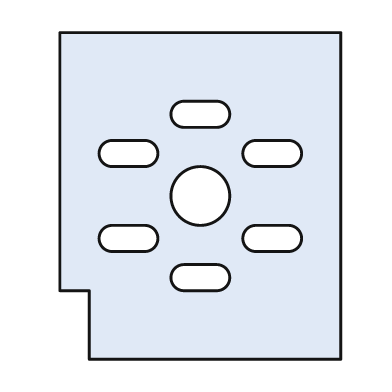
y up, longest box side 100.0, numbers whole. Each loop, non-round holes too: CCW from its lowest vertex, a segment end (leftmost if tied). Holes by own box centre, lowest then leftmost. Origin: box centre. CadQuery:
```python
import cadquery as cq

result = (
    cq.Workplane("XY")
    .moveTo(-34.0, -50.0)
    .lineTo(43.0, -50.0)
    .lineTo(43.0, 50.0)
    .lineTo(-43.0, 50.0)
    .lineTo(-43.0, -29.0)
    .lineTo(-34.0, -29.0)
    .close()
    .moveTo(-5.0, -29.0)
    .lineTo(5.0, -29.0)
    .threePointArc((9.0, -25.0), (5.0, -21.0))
    .lineTo(-5.0, -21.0)
    .threePointArc((-9.0, -25.0), (-5.0, -29.0))
    .close()
    .moveTo(-27.0, -17.0)
    .lineTo(-17.0, -17.0)
    .threePointArc((-13.0, -13.0), (-17.0, -9.0))
    .lineTo(-27.0, -9.0)
    .threePointArc((-31.0, -13.0), (-27.0, -17.0))
    .close()
    .moveTo(17.0, -17.0)
    .lineTo(27.0, -17.0)
    .threePointArc((31.0, -13.0), (27.0, -9.0))
    .lineTo(17.0, -9.0)
    .threePointArc((13.0, -13.0), (17.0, -17.0))
    .close()
    .moveTo(0.0, 0.0)
    .circle(9.0)
    .moveTo(-27.0, 9.0)
    .lineTo(-17.0, 9.0)
    .threePointArc((-13.0, 13.0), (-17.0, 17.0))
    .lineTo(-27.0, 17.0)
    .threePointArc((-31.0, 13.0), (-27.0, 9.0))
    .close()
    .moveTo(17.0, 9.0)
    .lineTo(27.0, 9.0)
    .threePointArc((31.0, 13.0), (27.0, 17.0))
    .lineTo(17.0, 17.0)
    .threePointArc((13.0, 13.0), (17.0, 9.0))
    .close()
    .moveTo(-5.0, 21.0)
    .lineTo(5.0, 21.0)
    .threePointArc((9.0, 25.0), (5.0, 29.0))
    .lineTo(-5.0, 29.0)
    .threePointArc((-9.0, 25.0), (-5.0, 21.0))
    .close()
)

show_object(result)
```